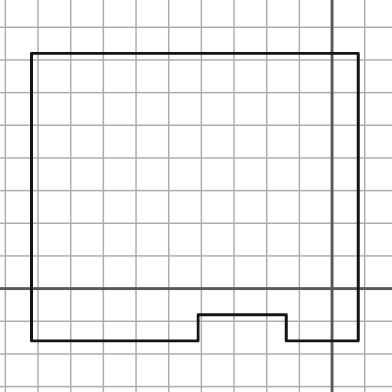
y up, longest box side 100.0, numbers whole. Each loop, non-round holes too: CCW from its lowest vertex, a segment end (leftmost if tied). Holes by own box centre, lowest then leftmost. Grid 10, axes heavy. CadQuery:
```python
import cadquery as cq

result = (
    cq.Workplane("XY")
    .moveTo(-92.0, -16.0)
    .lineTo(-41.0, -16.0)
    .lineTo(-41.0, -8.0)
    .lineTo(-14.0, -8.0)
    .lineTo(-14.0, -16.0)
    .lineTo(8.0, -16.0)
    .lineTo(8.0, 72.0)
    .lineTo(-92.0, 72.0)
    .close()
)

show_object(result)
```